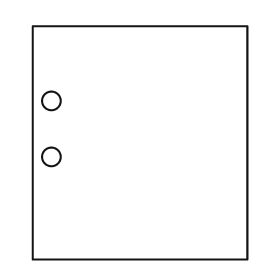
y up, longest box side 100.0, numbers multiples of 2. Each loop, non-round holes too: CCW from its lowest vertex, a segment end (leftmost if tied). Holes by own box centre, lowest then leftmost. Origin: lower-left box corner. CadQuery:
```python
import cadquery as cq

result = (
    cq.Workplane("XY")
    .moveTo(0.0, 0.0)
    .lineTo(92.0, 0.0)
    .lineTo(92.0, 100.0)
    .lineTo(0.0, 100.0)
    .close()
    .moveTo(8.0, 44.0)
    .circle(4.0)
    .moveTo(8.0, 68.0)
    .circle(4.0)
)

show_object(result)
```